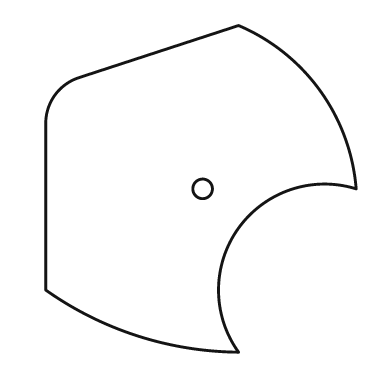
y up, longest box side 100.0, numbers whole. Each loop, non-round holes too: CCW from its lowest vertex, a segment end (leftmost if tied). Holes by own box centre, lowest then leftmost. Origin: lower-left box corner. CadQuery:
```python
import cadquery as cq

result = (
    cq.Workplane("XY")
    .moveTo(59.0, 0.0)
    .threePointArc((59.0, 38.0), (95.0, 50.0))
    .threePointArc((84.0, 80.0), (59.0, 100.0))
    .lineTo(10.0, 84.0)
    .threePointArc((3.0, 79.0), (0.0, 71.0))
    .lineTo(0.0, 19.0)
    .threePointArc((28.0, 5.0), (59.0, 0.0))
    .close()
    .moveTo(48.0, 50.0)
    .circle(3.0)
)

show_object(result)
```